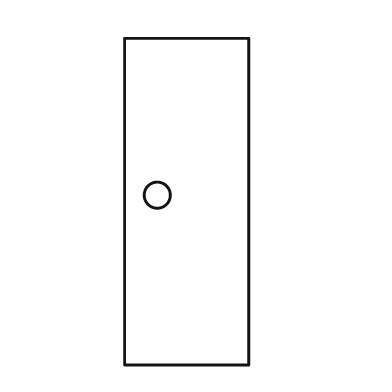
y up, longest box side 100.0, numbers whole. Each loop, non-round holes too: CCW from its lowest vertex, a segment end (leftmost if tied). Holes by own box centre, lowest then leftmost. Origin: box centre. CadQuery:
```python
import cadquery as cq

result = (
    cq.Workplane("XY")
    .moveTo(-19.0, -50.0)
    .lineTo(19.0, -50.0)
    .lineTo(19.0, 50.0)
    .lineTo(-19.0, 50.0)
    .close()
    .moveTo(-9.0, 2.0)
    .circle(4.0)
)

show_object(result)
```